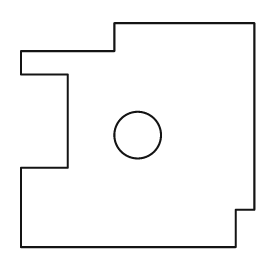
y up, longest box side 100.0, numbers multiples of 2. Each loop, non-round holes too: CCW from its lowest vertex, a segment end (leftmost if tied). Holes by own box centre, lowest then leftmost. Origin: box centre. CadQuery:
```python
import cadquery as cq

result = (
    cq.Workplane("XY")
    .moveTo(-50.0, -48.0)
    .lineTo(42.0, -48.0)
    .lineTo(42.0, -32.0)
    .lineTo(50.0, -32.0)
    .lineTo(50.0, 48.0)
    .lineTo(-10.0, 48.0)
    .lineTo(-10.0, 36.0)
    .lineTo(-50.0, 36.0)
    .lineTo(-50.0, 26.0)
    .lineTo(-30.0, 26.0)
    .lineTo(-30.0, -14.0)
    .lineTo(-50.0, -14.0)
    .close()
    .moveTo(0.0, 0.0)
    .circle(10.0)
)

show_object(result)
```